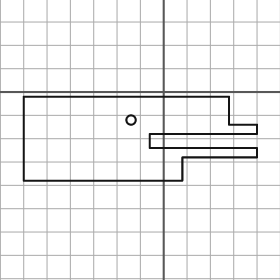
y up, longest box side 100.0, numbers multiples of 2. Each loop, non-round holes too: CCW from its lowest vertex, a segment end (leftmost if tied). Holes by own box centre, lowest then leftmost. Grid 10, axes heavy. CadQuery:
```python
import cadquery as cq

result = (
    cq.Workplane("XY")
    .moveTo(-60.0, -38.0)
    .lineTo(8.0, -38.0)
    .lineTo(8.0, -28.0)
    .lineTo(40.0, -28.0)
    .lineTo(40.0, -24.0)
    .lineTo(-6.0, -24.0)
    .lineTo(-6.0, -18.0)
    .lineTo(40.0, -18.0)
    .lineTo(40.0, -14.0)
    .lineTo(28.0, -14.0)
    .lineTo(28.0, -2.0)
    .lineTo(-60.0, -2.0)
    .close()
    .moveTo(-14.0, -12.0)
    .circle(2.0)
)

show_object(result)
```